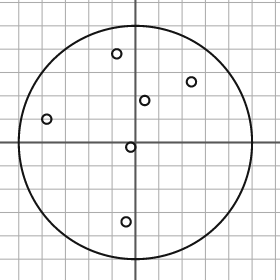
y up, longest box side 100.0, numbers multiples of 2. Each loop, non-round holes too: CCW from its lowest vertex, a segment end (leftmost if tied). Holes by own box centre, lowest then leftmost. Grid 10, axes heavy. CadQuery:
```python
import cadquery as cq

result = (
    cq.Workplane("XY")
    .moveTo(0.0, 0.0)
    .circle(50.0)
    .moveTo(-4.0, -34.0)
    .circle(2.0)
    .moveTo(-2.0, -2.0)
    .circle(2.0)
    .moveTo(-38.0, 10.0)
    .circle(2.0)
    .moveTo(4.0, 18.0)
    .circle(2.0)
    .moveTo(24.0, 26.0)
    .circle(2.0)
    .moveTo(-8.0, 38.0)
    .circle(2.0)
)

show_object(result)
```